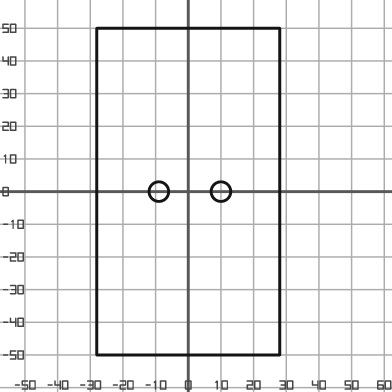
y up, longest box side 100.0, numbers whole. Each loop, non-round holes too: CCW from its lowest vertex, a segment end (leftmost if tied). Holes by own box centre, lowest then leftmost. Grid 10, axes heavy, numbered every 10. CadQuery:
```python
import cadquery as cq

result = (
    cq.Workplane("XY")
    .moveTo(-28.0, -50.0)
    .lineTo(28.0, -50.0)
    .lineTo(28.0, 50.0)
    .lineTo(-28.0, 50.0)
    .close()
    .moveTo(-9.0, 0.0)
    .circle(3.0)
    .moveTo(10.0, 0.0)
    .circle(3.0)
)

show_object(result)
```